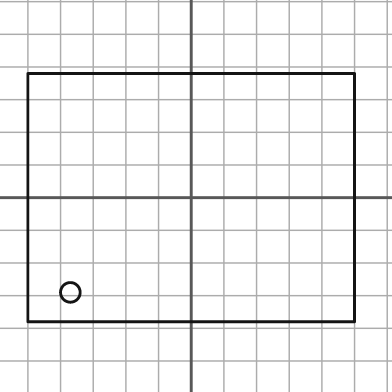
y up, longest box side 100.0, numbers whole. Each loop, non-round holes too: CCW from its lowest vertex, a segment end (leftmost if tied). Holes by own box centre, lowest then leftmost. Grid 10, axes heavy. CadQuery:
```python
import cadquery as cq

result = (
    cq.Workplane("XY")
    .moveTo(-50.0, -38.0)
    .lineTo(50.0, -38.0)
    .lineTo(50.0, 38.0)
    .lineTo(-50.0, 38.0)
    .close()
    .moveTo(-37.0, -29.0)
    .circle(3.0)
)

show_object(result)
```